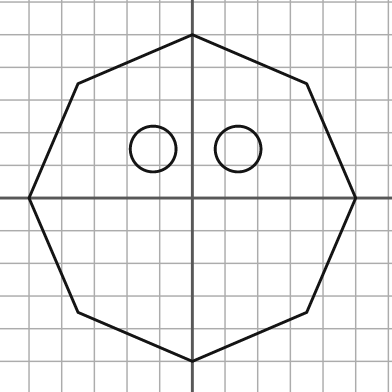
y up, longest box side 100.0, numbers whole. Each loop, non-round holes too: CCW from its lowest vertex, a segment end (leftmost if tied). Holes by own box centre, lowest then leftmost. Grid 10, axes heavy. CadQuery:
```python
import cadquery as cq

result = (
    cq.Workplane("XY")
    .moveTo(0.0, -50.0)
    .lineTo(35.0, -35.0)
    .lineTo(50.0, 0.0)
    .lineTo(35.0, 35.0)
    .lineTo(0.0, 50.0)
    .lineTo(-35.0, 35.0)
    .lineTo(-50.0, 0.0)
    .lineTo(-35.0, -35.0)
    .close()
    .moveTo(-12.0, 15.0)
    .circle(7.0)
    .moveTo(14.0, 15.0)
    .circle(7.0)
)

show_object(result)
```